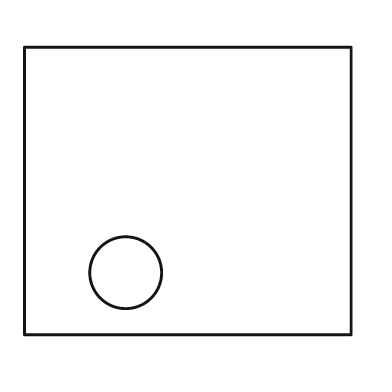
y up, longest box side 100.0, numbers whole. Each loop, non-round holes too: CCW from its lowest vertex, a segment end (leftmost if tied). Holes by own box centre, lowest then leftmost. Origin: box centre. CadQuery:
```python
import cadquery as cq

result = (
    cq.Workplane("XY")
    .moveTo(-50.0, -44.0)
    .lineTo(50.0, -44.0)
    .lineTo(50.0, 44.0)
    .lineTo(-50.0, 44.0)
    .close()
    .moveTo(-19.0, -25.0)
    .circle(11.0)
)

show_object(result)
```